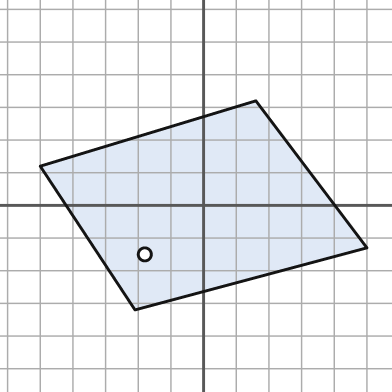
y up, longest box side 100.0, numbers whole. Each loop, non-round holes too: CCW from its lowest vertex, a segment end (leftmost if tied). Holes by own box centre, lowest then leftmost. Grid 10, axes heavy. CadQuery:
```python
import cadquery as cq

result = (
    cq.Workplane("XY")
    .moveTo(-21.0, -32.0)
    .lineTo(50.0, -13.0)
    .lineTo(16.0, 32.0)
    .lineTo(-50.0, 12.0)
    .close()
    .moveTo(-18.0, -15.0)
    .circle(2.0)
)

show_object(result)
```